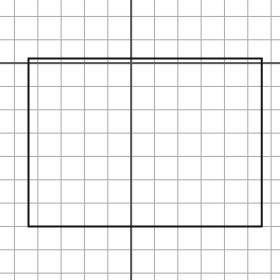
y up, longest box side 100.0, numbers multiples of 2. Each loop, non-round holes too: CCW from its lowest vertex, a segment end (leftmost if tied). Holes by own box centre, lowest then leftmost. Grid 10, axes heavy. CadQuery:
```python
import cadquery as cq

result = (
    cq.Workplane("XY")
    .moveTo(-44.0, -70.0)
    .lineTo(56.0, -70.0)
    .lineTo(56.0, 2.0)
    .lineTo(-44.0, 2.0)
    .close()
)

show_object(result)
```